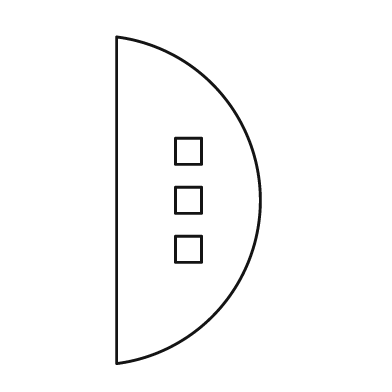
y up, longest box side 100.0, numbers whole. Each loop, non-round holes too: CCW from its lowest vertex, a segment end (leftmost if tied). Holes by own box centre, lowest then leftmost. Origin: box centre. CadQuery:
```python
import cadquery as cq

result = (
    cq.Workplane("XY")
    .moveTo(-22.0, -50.0)
    .threePointArc((22.0, 0.0), (-22.0, 50.0))
    .close()
    .moveTo(-4.0, -19.0)
    .lineTo(4.0, -19.0)
    .lineTo(4.0, -11.0)
    .lineTo(-4.0, -11.0)
    .close()
    .moveTo(-4.0, -4.0)
    .lineTo(4.0, -4.0)
    .lineTo(4.0, 4.0)
    .lineTo(-4.0, 4.0)
    .close()
    .moveTo(-4.0, 11.0)
    .lineTo(4.0, 11.0)
    .lineTo(4.0, 19.0)
    .lineTo(-4.0, 19.0)
    .close()
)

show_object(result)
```